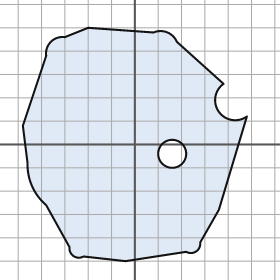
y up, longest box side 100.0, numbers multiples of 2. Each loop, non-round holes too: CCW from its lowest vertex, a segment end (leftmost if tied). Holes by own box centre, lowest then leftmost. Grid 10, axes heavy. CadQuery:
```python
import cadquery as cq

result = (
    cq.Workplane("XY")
    .moveTo(-4.0, -50.0)
    .lineTo(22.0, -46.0)
    .threePointArc((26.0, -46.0), (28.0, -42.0))
    .lineTo(36.0, -28.0)
    .lineTo(48.0, 12.0)
    .threePointArc((36.0, 14.0), (38.0, 26.0))
    .lineTo(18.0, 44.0)
    .threePointArc((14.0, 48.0), (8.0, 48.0))
    .lineTo(-20.0, 50.0)
    .lineTo(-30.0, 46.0)
    .threePointArc((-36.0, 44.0), (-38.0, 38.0))
    .lineTo(-48.0, 8.0)
    .lineTo(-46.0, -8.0)
    .threePointArc((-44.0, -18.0), (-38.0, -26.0))
    .lineTo(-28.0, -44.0)
    .threePointArc((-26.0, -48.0), (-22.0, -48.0))
    .close()
    .moveTo(16.0, -4.0)
    .circle(6.0)
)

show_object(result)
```